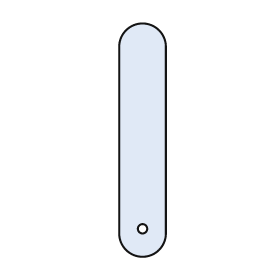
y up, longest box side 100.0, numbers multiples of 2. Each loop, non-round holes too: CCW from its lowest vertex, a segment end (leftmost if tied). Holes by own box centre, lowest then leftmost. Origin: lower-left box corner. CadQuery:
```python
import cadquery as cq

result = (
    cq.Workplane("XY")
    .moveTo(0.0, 10.0)
    .threePointArc((10.0, 0.0), (20.0, 10.0))
    .lineTo(20.0, 90.0)
    .threePointArc((10.0, 100.0), (0.0, 90.0))
    .close()
    .moveTo(10.0, 12.0)
    .circle(2.0)
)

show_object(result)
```